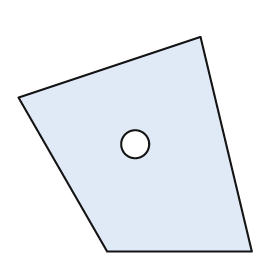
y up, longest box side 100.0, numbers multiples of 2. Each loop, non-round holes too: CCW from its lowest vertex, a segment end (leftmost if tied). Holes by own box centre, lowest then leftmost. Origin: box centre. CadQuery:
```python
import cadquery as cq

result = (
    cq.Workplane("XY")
    .moveTo(-12.0, -46.0)
    .lineTo(50.0, -46.0)
    .lineTo(28.0, 46.0)
    .lineTo(-50.0, 20.0)
    .close()
    .moveTo(0.0, 0.0)
    .circle(6.0)
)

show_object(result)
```